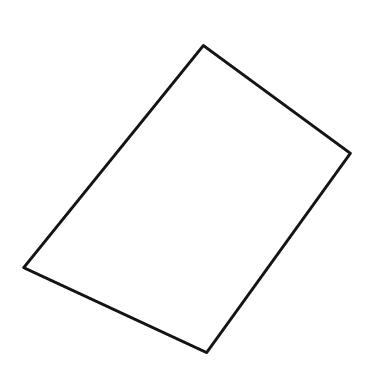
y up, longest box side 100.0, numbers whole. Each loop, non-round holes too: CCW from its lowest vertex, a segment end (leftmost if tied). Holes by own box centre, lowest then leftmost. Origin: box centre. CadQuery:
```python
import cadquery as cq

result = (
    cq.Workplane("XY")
    .moveTo(6.0, -47.0)
    .lineTo(50.0, 14.0)
    .lineTo(5.0, 47.0)
    .lineTo(-50.0, -21.0)
    .close()
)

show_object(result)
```